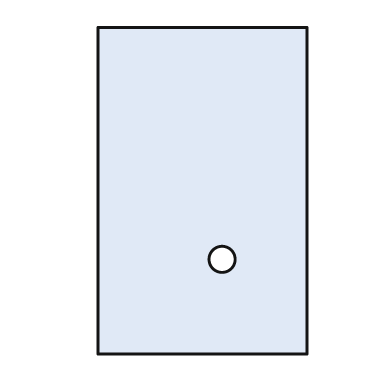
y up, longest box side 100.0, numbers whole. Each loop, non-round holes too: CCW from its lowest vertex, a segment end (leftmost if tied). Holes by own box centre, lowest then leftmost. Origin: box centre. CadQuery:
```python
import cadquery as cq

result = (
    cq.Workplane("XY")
    .moveTo(-32.0, -50.0)
    .lineTo(32.0, -50.0)
    .lineTo(32.0, 50.0)
    .lineTo(-32.0, 50.0)
    .close()
    .moveTo(6.0, -21.0)
    .circle(4.0)
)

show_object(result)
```